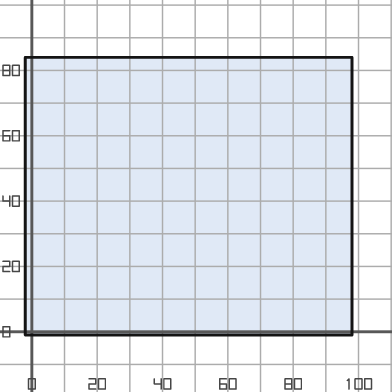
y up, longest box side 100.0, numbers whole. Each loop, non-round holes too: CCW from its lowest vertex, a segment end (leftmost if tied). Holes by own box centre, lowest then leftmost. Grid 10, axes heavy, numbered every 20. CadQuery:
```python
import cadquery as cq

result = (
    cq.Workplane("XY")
    .moveTo(-2.0, -1.0)
    .lineTo(98.0, -1.0)
    .lineTo(98.0, 84.0)
    .lineTo(-2.0, 84.0)
    .close()
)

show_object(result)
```